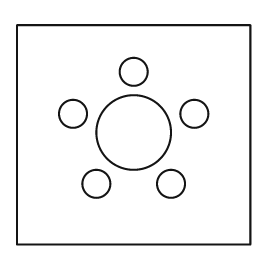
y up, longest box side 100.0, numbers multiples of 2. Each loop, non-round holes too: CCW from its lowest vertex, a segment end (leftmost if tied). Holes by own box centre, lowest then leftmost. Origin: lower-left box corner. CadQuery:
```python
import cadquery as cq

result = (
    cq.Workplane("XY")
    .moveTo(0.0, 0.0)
    .lineTo(100.0, 0.0)
    .lineTo(100.0, 94.0)
    .lineTo(0.0, 94.0)
    .close()
    .moveTo(34.0, 26.0)
    .circle(6.0)
    .moveTo(66.0, 26.0)
    .circle(6.0)
    .moveTo(50.0, 48.0)
    .circle(16.0)
    .moveTo(24.0, 56.0)
    .circle(6.0)
    .moveTo(76.0, 56.0)
    .circle(6.0)
    .moveTo(50.0, 74.0)
    .circle(6.0)
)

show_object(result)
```